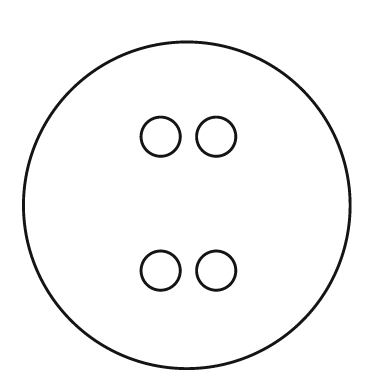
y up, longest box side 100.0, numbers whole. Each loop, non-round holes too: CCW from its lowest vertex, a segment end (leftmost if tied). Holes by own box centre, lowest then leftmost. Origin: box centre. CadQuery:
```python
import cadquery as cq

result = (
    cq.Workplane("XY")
    .moveTo(0.0, 0.0)
    .circle(50.0)
    .moveTo(-8.0, -20.0)
    .circle(6.0)
    .moveTo(9.0, -20.0)
    .circle(6.0)
    .moveTo(-8.0, 21.0)
    .circle(6.0)
    .moveTo(9.0, 21.0)
    .circle(6.0)
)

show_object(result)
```